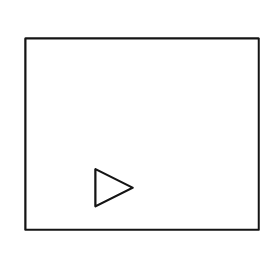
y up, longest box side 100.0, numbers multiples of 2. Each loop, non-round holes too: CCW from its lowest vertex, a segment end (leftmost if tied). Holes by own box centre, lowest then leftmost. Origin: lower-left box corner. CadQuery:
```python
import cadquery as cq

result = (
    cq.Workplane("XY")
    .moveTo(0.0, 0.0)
    .lineTo(100.0, 0.0)
    .lineTo(100.0, 82.0)
    .lineTo(0.0, 82.0)
    .close()
    .moveTo(30.0, 10.0)
    .lineTo(46.0, 18.0)
    .lineTo(30.0, 26.0)
    .close()
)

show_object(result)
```